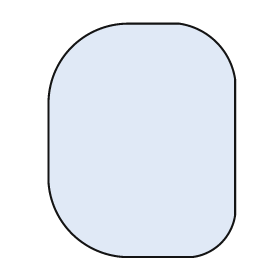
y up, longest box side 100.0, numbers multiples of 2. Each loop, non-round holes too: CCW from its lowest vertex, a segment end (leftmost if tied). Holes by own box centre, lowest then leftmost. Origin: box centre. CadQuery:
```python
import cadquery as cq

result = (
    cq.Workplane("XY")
    .moveTo(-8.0, -50.0)
    .lineTo(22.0, -50.0)
    .threePointArc((34.0, -44.0), (40.0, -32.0))
    .lineTo(40.0, 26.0)
    .threePointArc((32.0, 42.0), (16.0, 50.0))
    .lineTo(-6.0, 50.0)
    .threePointArc((-30.0, 40.0), (-40.0, 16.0))
    .lineTo(-40.0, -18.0)
    .threePointArc((-30.0, -40.0), (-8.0, -50.0))
    .close()
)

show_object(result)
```